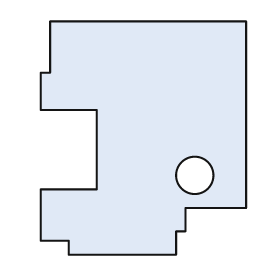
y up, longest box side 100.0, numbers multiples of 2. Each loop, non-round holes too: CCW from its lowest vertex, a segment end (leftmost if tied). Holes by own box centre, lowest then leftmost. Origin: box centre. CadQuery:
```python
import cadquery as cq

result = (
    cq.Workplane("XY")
    .moveTo(-32.0, -50.0)
    .lineTo(14.0, -50.0)
    .lineTo(14.0, -40.0)
    .lineTo(18.0, -40.0)
    .lineTo(18.0, -30.0)
    .lineTo(44.0, -30.0)
    .lineTo(44.0, 50.0)
    .lineTo(-40.0, 50.0)
    .lineTo(-40.0, 28.0)
    .lineTo(-44.0, 28.0)
    .lineTo(-44.0, 12.0)
    .lineTo(-20.0, 12.0)
    .lineTo(-20.0, -22.0)
    .lineTo(-44.0, -22.0)
    .lineTo(-44.0, -44.0)
    .lineTo(-32.0, -44.0)
    .close()
    .moveTo(22.0, -16.0)
    .circle(8.0)
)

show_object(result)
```